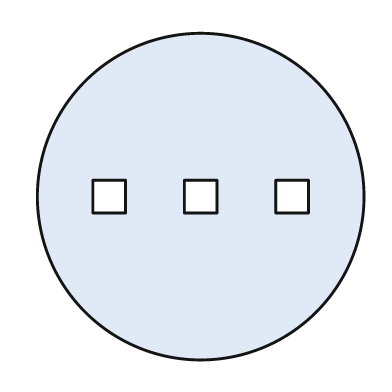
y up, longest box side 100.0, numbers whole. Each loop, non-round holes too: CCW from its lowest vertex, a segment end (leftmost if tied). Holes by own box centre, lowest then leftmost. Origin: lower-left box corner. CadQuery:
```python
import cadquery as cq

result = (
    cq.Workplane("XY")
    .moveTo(50.0, 50.0)
    .circle(50.0)
    .moveTo(17.0, 45.0)
    .lineTo(27.0, 45.0)
    .lineTo(27.0, 55.0)
    .lineTo(17.0, 55.0)
    .close()
    .moveTo(45.0, 45.0)
    .lineTo(55.0, 45.0)
    .lineTo(55.0, 55.0)
    .lineTo(45.0, 55.0)
    .close()
    .moveTo(73.0, 45.0)
    .lineTo(83.0, 45.0)
    .lineTo(83.0, 55.0)
    .lineTo(73.0, 55.0)
    .close()
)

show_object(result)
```